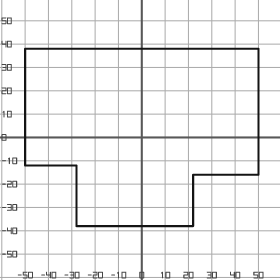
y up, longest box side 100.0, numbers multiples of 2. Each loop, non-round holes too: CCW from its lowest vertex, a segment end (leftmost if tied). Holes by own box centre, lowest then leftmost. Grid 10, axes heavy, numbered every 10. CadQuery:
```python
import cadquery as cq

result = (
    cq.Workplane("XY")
    .moveTo(-28.0, -38.0)
    .lineTo(22.0, -38.0)
    .lineTo(22.0, -16.0)
    .lineTo(50.0, -16.0)
    .lineTo(50.0, 38.0)
    .lineTo(-50.0, 38.0)
    .lineTo(-50.0, -12.0)
    .lineTo(-28.0, -12.0)
    .close()
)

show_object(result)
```